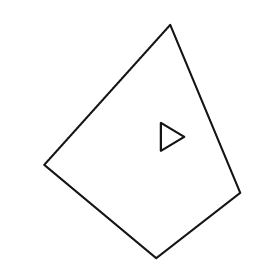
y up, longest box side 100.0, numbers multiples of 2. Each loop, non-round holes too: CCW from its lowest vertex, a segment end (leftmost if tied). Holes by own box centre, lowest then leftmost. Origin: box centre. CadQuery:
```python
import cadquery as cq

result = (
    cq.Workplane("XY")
    .moveTo(6.0, -50.0)
    .lineTo(42.0, -22.0)
    .lineTo(12.0, 50.0)
    .lineTo(-42.0, -10.0)
    .close()
    .moveTo(8.0, -4.0)
    .lineTo(18.0, 2.0)
    .lineTo(8.0, 8.0)
    .close()
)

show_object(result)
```